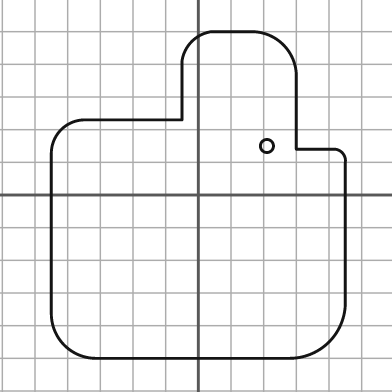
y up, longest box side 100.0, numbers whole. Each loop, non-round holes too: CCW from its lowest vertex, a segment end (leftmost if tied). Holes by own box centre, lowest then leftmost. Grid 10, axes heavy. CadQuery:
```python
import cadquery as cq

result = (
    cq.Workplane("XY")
    .moveTo(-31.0, -50.0)
    .lineTo(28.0, -50.0)
    .threePointArc((40.0, -45.0), (45.0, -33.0))
    .lineTo(45.0, 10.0)
    .threePointArc((44.0, 13.0), (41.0, 14.0))
    .lineTo(30.0, 14.0)
    .lineTo(30.0, 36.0)
    .threePointArc((26.0, 46.0), (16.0, 50.0))
    .lineTo(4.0, 50.0)
    .threePointArc((-2.0, 47.0), (-5.0, 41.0))
    .lineTo(-5.0, 23.0)
    .lineTo(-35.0, 23.0)
    .threePointArc((-42.0, 20.0), (-45.0, 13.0))
    .lineTo(-45.0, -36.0)
    .threePointArc((-41.0, -46.0), (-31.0, -50.0))
    .close()
    .moveTo(21.0, 15.0)
    .circle(2.0)
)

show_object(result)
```